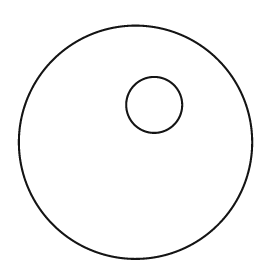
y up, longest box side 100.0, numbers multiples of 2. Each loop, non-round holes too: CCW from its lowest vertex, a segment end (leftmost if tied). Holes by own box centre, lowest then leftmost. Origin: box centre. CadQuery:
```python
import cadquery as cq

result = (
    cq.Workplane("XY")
    .moveTo(0.0, 0.0)
    .circle(50.0)
    .moveTo(8.0, 16.0)
    .circle(12.0)
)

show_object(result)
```